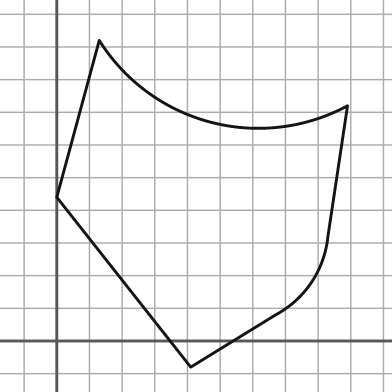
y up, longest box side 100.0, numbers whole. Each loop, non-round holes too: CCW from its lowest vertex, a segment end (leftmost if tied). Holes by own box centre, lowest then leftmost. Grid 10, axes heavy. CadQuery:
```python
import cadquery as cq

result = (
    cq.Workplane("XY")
    .moveTo(41.0, -8.0)
    .lineTo(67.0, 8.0)
    .threePointArc((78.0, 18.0), (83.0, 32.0))
    .lineTo(89.0, 72.0)
    .threePointArc((47.0, 67.0), (13.0, 92.0))
    .lineTo(0.0, 44.0)
    .close()
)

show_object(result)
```